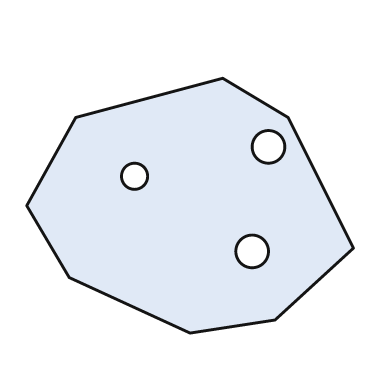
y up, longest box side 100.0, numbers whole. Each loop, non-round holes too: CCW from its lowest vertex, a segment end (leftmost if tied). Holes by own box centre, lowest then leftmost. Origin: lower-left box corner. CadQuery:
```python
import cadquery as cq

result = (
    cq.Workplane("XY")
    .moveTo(50.0, 0.0)
    .lineTo(76.0, 4.0)
    .lineTo(100.0, 26.0)
    .lineTo(80.0, 66.0)
    .lineTo(60.0, 78.0)
    .lineTo(15.0, 66.0)
    .lineTo(0.0, 39.0)
    .lineTo(13.0, 17.0)
    .close()
    .moveTo(69.0, 25.0)
    .circle(5.0)
    .moveTo(33.0, 48.0)
    .circle(4.0)
    .moveTo(74.0, 57.0)
    .circle(5.0)
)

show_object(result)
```